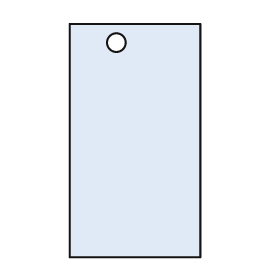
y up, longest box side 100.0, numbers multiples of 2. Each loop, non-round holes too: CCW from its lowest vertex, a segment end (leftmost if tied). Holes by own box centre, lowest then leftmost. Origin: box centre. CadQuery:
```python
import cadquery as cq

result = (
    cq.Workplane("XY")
    .moveTo(-28.0, -50.0)
    .lineTo(28.0, -50.0)
    .lineTo(28.0, 50.0)
    .lineTo(-28.0, 50.0)
    .close()
    .moveTo(-8.0, 42.0)
    .circle(4.0)
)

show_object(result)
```